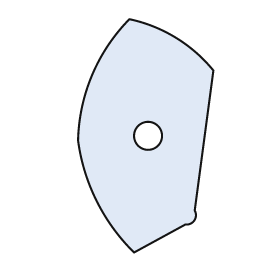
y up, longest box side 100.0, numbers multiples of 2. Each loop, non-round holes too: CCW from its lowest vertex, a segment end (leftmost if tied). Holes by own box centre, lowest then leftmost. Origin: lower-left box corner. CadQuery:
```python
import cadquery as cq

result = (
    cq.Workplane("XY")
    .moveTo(24.0, 0.0)
    .lineTo(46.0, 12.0)
    .threePointArc((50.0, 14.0), (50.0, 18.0))
    .lineTo(58.0, 78.0)
    .threePointArc((42.0, 92.0), (22.0, 100.0))
    .threePointArc((6.0, 76.0), (0.0, 48.0))
    .threePointArc((8.0, 22.0), (24.0, 0.0))
    .close()
    .moveTo(30.0, 50.0)
    .circle(6.0)
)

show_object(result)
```